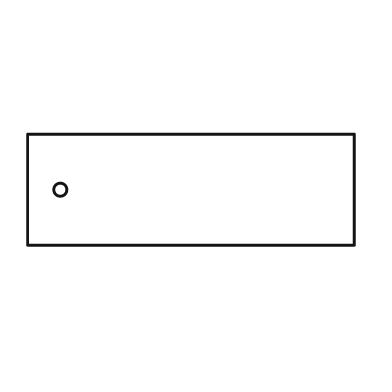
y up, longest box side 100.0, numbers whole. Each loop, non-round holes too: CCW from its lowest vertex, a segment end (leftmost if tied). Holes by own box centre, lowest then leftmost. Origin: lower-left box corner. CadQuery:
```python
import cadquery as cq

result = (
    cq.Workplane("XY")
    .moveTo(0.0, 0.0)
    .lineTo(100.0, 0.0)
    .lineTo(100.0, 34.0)
    .lineTo(0.0, 34.0)
    .close()
    .moveTo(10.0, 17.0)
    .circle(2.0)
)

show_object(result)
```